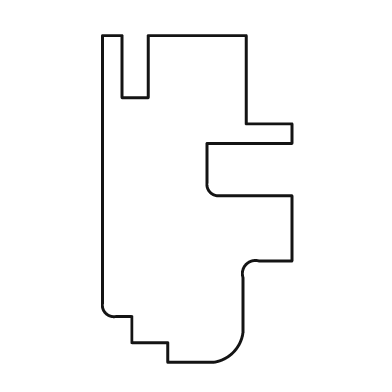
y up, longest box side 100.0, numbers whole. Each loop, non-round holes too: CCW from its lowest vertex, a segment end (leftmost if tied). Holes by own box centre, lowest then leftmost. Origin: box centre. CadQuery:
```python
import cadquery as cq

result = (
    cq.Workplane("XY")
    .moveTo(-9.0, -50.0)
    .lineTo(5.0, -50.0)
    .threePointArc((11.0, -47.0), (14.0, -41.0))
    .lineTo(14.0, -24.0)
    .threePointArc((15.0, -20.0), (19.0, -19.0))
    .lineTo(29.0, -19.0)
    .lineTo(29.0, 1.0)
    .lineTo(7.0, 1.0)
    .threePointArc((4.0, 2.0), (3.0, 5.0))
    .lineTo(3.0, 17.0)
    .lineTo(29.0, 17.0)
    .lineTo(29.0, 23.0)
    .lineTo(15.0, 23.0)
    .lineTo(15.0, 50.0)
    .lineTo(-15.0, 50.0)
    .lineTo(-15.0, 31.0)
    .lineTo(-23.0, 31.0)
    .lineTo(-23.0, 50.0)
    .lineTo(-29.0, 50.0)
    .lineTo(-29.0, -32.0)
    .threePointArc((-28.0, -35.0), (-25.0, -36.0))
    .lineTo(-20.0, -36.0)
    .lineTo(-20.0, -44.0)
    .lineTo(-9.0, -44.0)
    .close()
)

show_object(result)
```